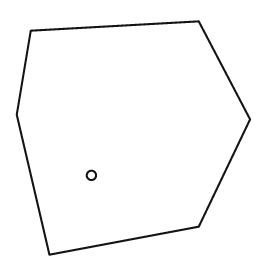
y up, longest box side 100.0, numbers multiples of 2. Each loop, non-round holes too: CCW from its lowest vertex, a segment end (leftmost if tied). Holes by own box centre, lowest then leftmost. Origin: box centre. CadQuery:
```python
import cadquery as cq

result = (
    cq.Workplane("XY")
    .moveTo(-36.0, -50.0)
    .lineTo(28.0, -38.0)
    .lineTo(50.0, 8.0)
    .lineTo(28.0, 50.0)
    .lineTo(-44.0, 46.0)
    .lineTo(-50.0, 10.0)
    .close()
    .moveTo(-18.0, -16.0)
    .circle(2.0)
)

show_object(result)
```